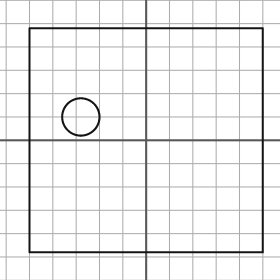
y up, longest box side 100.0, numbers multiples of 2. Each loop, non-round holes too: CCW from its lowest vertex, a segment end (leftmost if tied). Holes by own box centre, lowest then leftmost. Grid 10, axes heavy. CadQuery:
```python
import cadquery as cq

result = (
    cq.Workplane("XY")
    .moveTo(-50.0, -48.0)
    .lineTo(50.0, -48.0)
    .lineTo(50.0, 48.0)
    .lineTo(-50.0, 48.0)
    .close()
    .moveTo(-28.0, 10.0)
    .circle(8.0)
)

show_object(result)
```